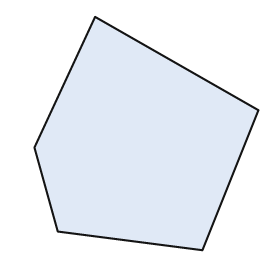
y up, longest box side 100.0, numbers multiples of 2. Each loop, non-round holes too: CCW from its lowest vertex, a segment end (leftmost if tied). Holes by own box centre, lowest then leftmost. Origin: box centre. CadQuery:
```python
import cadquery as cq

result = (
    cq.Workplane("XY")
    .moveTo(24.0, -50.0)
    .lineTo(48.0, 10.0)
    .lineTo(-22.0, 50.0)
    .lineTo(-48.0, -6.0)
    .lineTo(-38.0, -42.0)
    .close()
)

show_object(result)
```